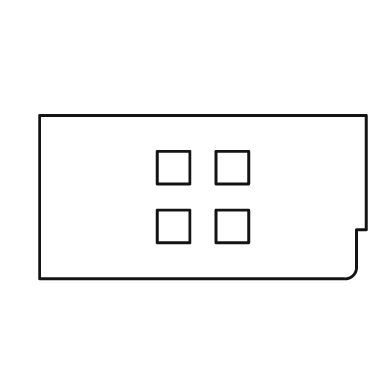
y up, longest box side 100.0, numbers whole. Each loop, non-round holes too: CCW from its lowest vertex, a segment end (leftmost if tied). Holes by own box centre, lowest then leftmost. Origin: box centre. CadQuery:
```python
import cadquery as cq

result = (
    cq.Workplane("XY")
    .moveTo(-50.0, -25.0)
    .lineTo(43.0, -25.0)
    .threePointArc((46.0, -24.0), (47.0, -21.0))
    .lineTo(47.0, -10.0)
    .lineTo(50.0, -10.0)
    .lineTo(50.0, 25.0)
    .lineTo(-50.0, 25.0)
    .close()
    .moveTo(-14.0, -14.0)
    .lineTo(-4.0, -14.0)
    .lineTo(-4.0, -4.0)
    .lineTo(-14.0, -4.0)
    .close()
    .moveTo(4.0, -14.0)
    .lineTo(14.0, -14.0)
    .lineTo(14.0, -4.0)
    .lineTo(4.0, -4.0)
    .close()
    .moveTo(-14.0, 4.0)
    .lineTo(-4.0, 4.0)
    .lineTo(-4.0, 14.0)
    .lineTo(-14.0, 14.0)
    .close()
    .moveTo(4.0, 4.0)
    .lineTo(14.0, 4.0)
    .lineTo(14.0, 14.0)
    .lineTo(4.0, 14.0)
    .close()
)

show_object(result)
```